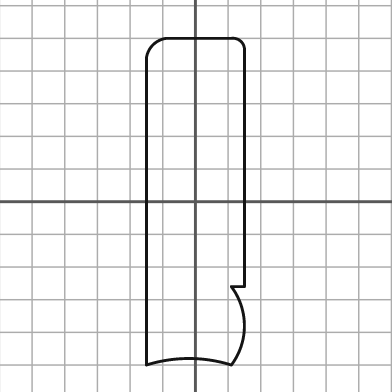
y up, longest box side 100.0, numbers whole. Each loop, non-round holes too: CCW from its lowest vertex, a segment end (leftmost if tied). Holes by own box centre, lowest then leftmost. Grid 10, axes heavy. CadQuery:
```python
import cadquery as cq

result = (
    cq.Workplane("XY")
    .moveTo(-15.0, -50.0)
    .threePointArc((-2.0, -48.0), (11.0, -50.0))
    .threePointArc((15.0, -38.0), (11.0, -26.0))
    .lineTo(15.0, -26.0)
    .lineTo(15.0, 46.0)
    .threePointArc((14.0, 49.0), (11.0, 50.0))
    .lineTo(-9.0, 50.0)
    .threePointArc((-13.0, 48.0), (-15.0, 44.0))
    .close()
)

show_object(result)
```